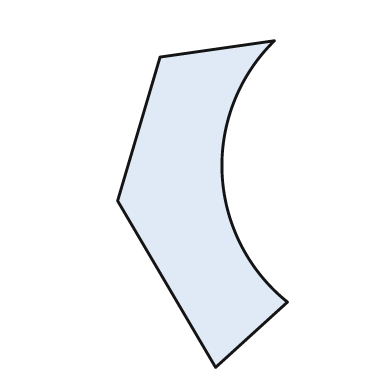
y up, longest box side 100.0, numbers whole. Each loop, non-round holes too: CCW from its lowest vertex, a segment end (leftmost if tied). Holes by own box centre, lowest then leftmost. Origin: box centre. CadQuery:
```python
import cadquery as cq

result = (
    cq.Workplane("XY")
    .moveTo(4.0, -50.0)
    .lineTo(26.0, -30.0)
    .threePointArc((6.0, 9.0), (22.0, 50.0))
    .lineTo(-13.0, 45.0)
    .lineTo(-26.0, 1.0)
    .close()
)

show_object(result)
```